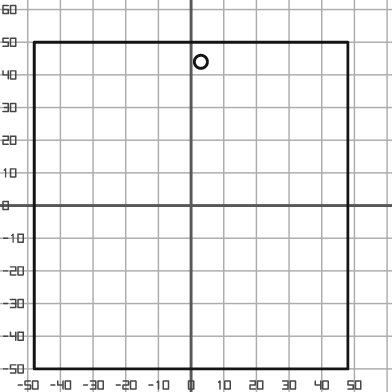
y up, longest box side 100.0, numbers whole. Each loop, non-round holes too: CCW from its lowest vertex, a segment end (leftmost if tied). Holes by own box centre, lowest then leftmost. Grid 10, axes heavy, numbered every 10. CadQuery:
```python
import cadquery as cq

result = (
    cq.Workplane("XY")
    .moveTo(-48.0, -50.0)
    .lineTo(48.0, -50.0)
    .lineTo(48.0, 50.0)
    .lineTo(-48.0, 50.0)
    .close()
    .moveTo(3.0, 44.0)
    .circle(2.0)
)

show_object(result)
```